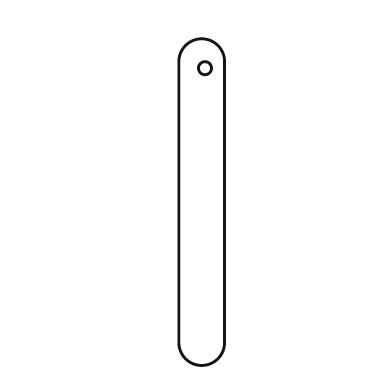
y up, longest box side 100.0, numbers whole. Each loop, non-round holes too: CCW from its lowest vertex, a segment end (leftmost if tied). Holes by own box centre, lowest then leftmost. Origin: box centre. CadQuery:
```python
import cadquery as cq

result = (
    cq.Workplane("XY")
    .moveTo(-7.0, -43.0)
    .threePointArc((0.0, -50.0), (7.0, -43.0))
    .lineTo(7.0, 43.0)
    .threePointArc((0.0, 50.0), (-7.0, 43.0))
    .close()
    .moveTo(1.0, 41.0)
    .circle(2.0)
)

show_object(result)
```